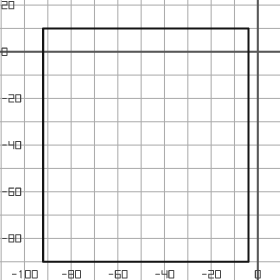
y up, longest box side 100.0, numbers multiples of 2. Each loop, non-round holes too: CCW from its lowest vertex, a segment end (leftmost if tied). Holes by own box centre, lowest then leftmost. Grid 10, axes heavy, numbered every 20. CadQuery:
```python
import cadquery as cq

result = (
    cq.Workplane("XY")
    .moveTo(-92.0, -90.0)
    .lineTo(-4.0, -90.0)
    .lineTo(-4.0, 10.0)
    .lineTo(-92.0, 10.0)
    .close()
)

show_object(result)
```